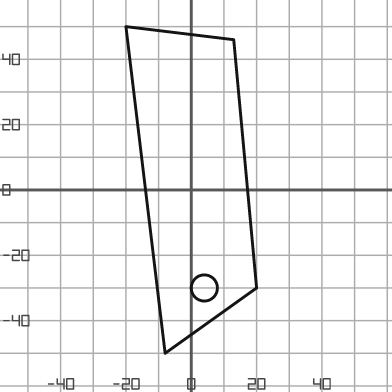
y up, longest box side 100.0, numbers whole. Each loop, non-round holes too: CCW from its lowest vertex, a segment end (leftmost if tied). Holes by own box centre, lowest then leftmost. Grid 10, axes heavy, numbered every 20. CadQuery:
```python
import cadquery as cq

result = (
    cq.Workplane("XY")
    .moveTo(-8.0, -50.0)
    .lineTo(20.0, -30.0)
    .lineTo(13.0, 46.0)
    .lineTo(-20.0, 50.0)
    .close()
    .moveTo(4.0, -30.0)
    .circle(4.0)
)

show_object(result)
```